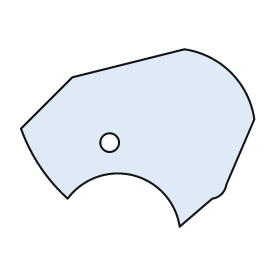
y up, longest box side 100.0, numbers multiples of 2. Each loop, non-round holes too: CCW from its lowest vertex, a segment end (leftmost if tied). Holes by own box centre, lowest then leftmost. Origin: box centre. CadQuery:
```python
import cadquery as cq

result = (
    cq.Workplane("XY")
    .moveTo(18.0, -38.0)
    .lineTo(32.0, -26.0)
    .threePointArc((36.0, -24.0), (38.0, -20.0))
    .lineTo(50.0, 8.0)
    .threePointArc((40.0, 28.0), (20.0, 38.0))
    .lineTo(-28.0, 26.0)
    .lineTo(-50.0, 4.0)
    .threePointArc((-42.0, -12.0), (-30.0, -26.0))
    .threePointArc((-2.0, -16.0), (18.0, -38.0))
    .close()
    .moveTo(-12.0, -2.0)
    .circle(4.0)
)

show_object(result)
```